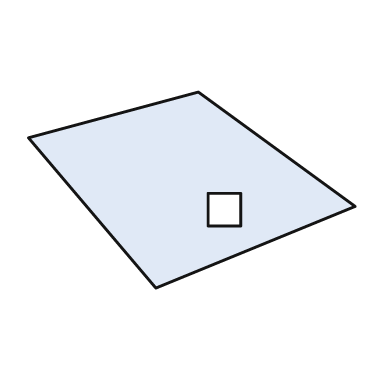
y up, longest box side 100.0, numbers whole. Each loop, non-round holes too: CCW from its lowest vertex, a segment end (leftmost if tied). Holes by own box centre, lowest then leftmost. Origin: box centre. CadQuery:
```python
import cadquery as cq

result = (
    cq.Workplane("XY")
    .moveTo(-11.0, -30.0)
    .lineTo(50.0, -5.0)
    .lineTo(2.0, 30.0)
    .lineTo(-50.0, 16.0)
    .close()
    .moveTo(5.0, -11.0)
    .lineTo(15.0, -11.0)
    .lineTo(15.0, -1.0)
    .lineTo(5.0, -1.0)
    .close()
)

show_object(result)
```